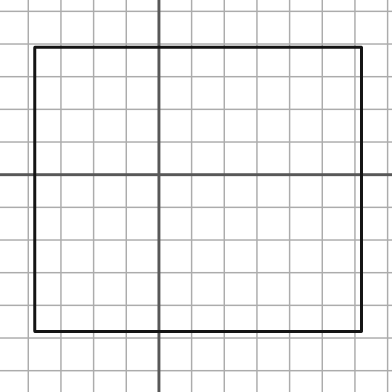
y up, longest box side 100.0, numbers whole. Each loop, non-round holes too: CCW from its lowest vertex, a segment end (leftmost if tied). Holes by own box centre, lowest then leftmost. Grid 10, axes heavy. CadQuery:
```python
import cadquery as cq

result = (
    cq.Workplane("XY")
    .moveTo(-38.0, -48.0)
    .lineTo(62.0, -48.0)
    .lineTo(62.0, 39.0)
    .lineTo(-38.0, 39.0)
    .close()
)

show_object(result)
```